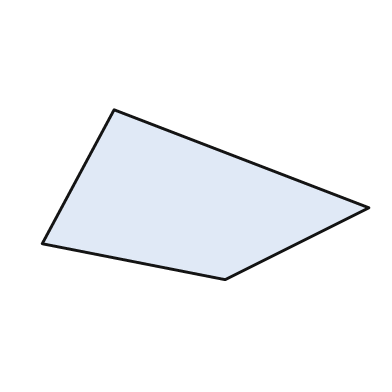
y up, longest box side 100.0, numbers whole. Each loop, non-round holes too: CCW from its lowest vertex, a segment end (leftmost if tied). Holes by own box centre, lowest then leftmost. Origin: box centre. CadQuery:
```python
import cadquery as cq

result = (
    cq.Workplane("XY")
    .moveTo(6.0, -26.0)
    .lineTo(50.0, -4.0)
    .lineTo(-28.0, 26.0)
    .lineTo(-50.0, -15.0)
    .close()
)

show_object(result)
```